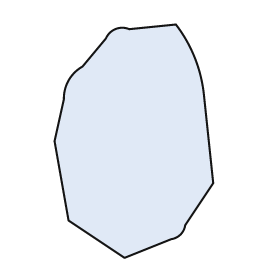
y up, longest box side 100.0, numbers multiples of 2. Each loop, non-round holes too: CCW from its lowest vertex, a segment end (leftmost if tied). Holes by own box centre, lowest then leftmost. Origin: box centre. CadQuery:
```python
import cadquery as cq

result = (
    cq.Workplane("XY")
    .moveTo(-4.0, -50.0)
    .lineTo(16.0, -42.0)
    .threePointArc((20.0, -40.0), (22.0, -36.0))
    .lineTo(34.0, -18.0)
    .lineTo(30.0, 20.0)
    .threePointArc((26.0, 36.0), (18.0, 50.0))
    .lineTo(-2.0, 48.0)
    .threePointArc((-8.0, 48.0), (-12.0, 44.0))
    .lineTo(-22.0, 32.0)
    .threePointArc((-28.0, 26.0), (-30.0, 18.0))
    .lineTo(-34.0, 0.0)
    .lineTo(-28.0, -34.0)
    .close()
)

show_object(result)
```